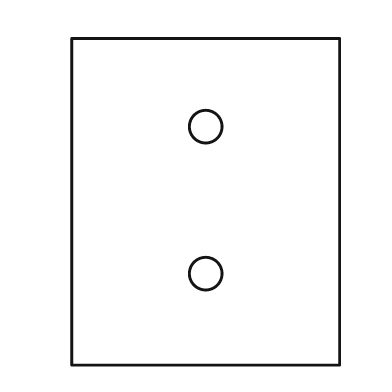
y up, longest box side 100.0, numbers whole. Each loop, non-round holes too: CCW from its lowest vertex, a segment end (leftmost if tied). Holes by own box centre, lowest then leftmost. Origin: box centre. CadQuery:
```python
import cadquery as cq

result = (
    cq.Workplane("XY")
    .moveTo(-41.0, -50.0)
    .lineTo(41.0, -50.0)
    .lineTo(41.0, 50.0)
    .lineTo(-41.0, 50.0)
    .close()
    .moveTo(0.0, -22.0)
    .circle(5.0)
    .moveTo(0.0, 23.0)
    .circle(5.0)
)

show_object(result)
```